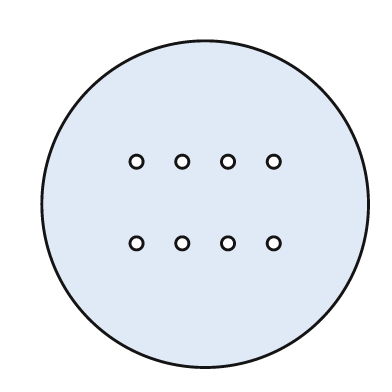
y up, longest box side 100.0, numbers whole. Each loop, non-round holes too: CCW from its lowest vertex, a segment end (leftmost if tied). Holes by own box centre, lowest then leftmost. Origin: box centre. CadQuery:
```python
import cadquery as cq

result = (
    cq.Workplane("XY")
    .moveTo(0.0, 0.0)
    .circle(50.0)
    .moveTo(-21.0, -12.0)
    .circle(2.0)
    .moveTo(-7.0, -12.0)
    .circle(2.0)
    .moveTo(7.0, -12.0)
    .circle(2.0)
    .moveTo(21.0, -12.0)
    .circle(2.0)
    .moveTo(-21.0, 13.0)
    .circle(2.0)
    .moveTo(-7.0, 13.0)
    .circle(2.0)
    .moveTo(7.0, 13.0)
    .circle(2.0)
    .moveTo(21.0, 13.0)
    .circle(2.0)
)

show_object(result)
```